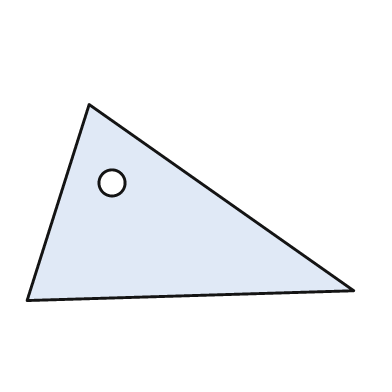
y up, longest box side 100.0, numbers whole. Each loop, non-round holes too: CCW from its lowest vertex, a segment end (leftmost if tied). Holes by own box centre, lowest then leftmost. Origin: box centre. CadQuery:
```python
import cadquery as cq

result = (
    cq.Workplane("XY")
    .moveTo(-50.0, -30.0)
    .lineTo(50.0, -27.0)
    .lineTo(-31.0, 30.0)
    .close()
    .moveTo(-24.0, 6.0)
    .circle(4.0)
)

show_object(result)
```